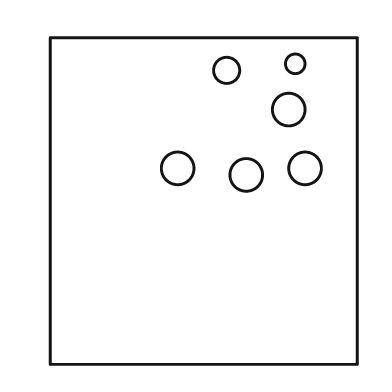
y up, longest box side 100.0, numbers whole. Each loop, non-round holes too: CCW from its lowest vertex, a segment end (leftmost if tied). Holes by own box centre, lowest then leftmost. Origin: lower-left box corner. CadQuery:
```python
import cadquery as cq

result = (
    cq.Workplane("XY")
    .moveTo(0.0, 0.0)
    .lineTo(94.0, 0.0)
    .lineTo(94.0, 100.0)
    .lineTo(0.0, 100.0)
    .close()
    .moveTo(60.0, 58.0)
    .circle(5.0)
    .moveTo(39.0, 60.0)
    .circle(5.0)
    .moveTo(78.0, 60.0)
    .circle(5.0)
    .moveTo(73.0, 78.0)
    .circle(5.0)
    .moveTo(54.0, 90.0)
    .circle(4.0)
    .moveTo(75.0, 92.0)
    .circle(3.0)
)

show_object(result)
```